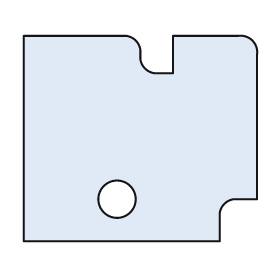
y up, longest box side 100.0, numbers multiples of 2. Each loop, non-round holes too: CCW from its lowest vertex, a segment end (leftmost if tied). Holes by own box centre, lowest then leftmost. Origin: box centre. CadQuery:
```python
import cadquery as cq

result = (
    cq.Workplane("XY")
    .moveTo(-50.0, -44.0)
    .lineTo(34.0, -44.0)
    .lineTo(34.0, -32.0)
    .threePointArc((36.0, -28.0), (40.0, -26.0))
    .lineTo(50.0, -26.0)
    .lineTo(50.0, 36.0)
    .threePointArc((48.0, 42.0), (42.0, 44.0))
    .lineTo(14.0, 44.0)
    .lineTo(14.0, 28.0)
    .lineTo(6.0, 28.0)
    .threePointArc((2.0, 30.0), (0.0, 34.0))
    .lineTo(0.0, 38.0)
    .threePointArc((-2.0, 42.0), (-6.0, 44.0))
    .lineTo(-50.0, 44.0)
    .close()
    .moveTo(-10.0, -26.0)
    .circle(8.0)
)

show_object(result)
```